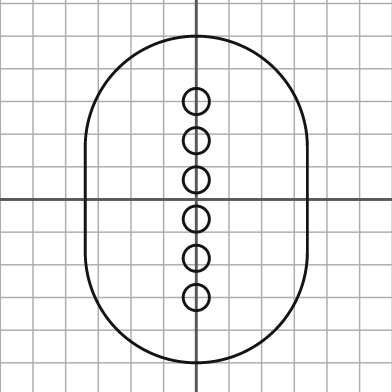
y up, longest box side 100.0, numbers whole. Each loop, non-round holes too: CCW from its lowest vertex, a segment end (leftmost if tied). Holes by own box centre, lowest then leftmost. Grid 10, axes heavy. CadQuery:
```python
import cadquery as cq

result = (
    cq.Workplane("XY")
    .moveTo(-34.0, -16.0)
    .threePointArc((0.0, -50.0), (34.0, -16.0))
    .lineTo(34.0, 16.0)
    .threePointArc((0.0, 50.0), (-34.0, 16.0))
    .close()
    .moveTo(0.0, -30.0)
    .circle(4.0)
    .moveTo(0.0, -18.0)
    .circle(4.0)
    .moveTo(0.0, -6.0)
    .circle(4.0)
    .moveTo(0.0, 6.0)
    .circle(4.0)
    .moveTo(0.0, 18.0)
    .circle(4.0)
    .moveTo(0.0, 30.0)
    .circle(4.0)
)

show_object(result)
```